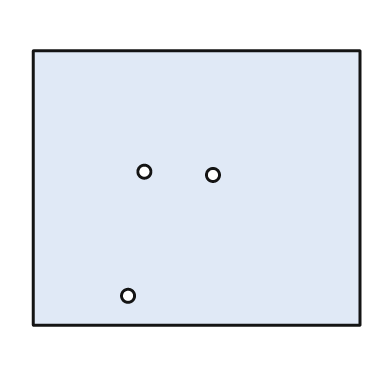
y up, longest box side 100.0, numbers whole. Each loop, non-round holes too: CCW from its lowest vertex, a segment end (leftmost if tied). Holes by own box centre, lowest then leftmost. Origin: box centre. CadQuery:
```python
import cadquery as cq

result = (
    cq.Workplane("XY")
    .moveTo(-50.0, -42.0)
    .lineTo(50.0, -42.0)
    .lineTo(50.0, 42.0)
    .lineTo(-50.0, 42.0)
    .close()
    .moveTo(-21.0, -33.0)
    .circle(2.0)
    .moveTo(5.0, 4.0)
    .circle(2.0)
    .moveTo(-16.0, 5.0)
    .circle(2.0)
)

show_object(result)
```